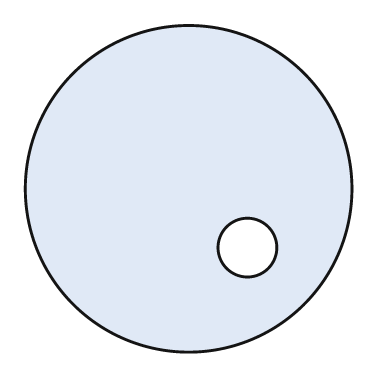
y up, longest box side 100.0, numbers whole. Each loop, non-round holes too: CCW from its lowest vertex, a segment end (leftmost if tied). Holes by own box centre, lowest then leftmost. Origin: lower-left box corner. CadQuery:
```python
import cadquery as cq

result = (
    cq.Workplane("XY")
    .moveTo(50.0, 50.0)
    .circle(50.0)
    .moveTo(68.0, 32.0)
    .circle(9.0)
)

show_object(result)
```